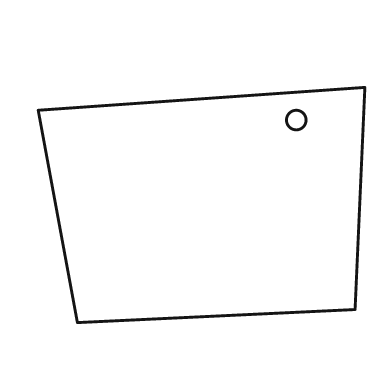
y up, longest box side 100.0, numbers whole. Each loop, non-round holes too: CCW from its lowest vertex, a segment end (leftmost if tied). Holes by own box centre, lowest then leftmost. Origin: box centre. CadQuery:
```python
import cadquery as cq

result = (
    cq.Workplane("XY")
    .moveTo(-38.0, -36.0)
    .lineTo(47.0, -32.0)
    .lineTo(50.0, 36.0)
    .lineTo(-50.0, 29.0)
    .close()
    .moveTo(29.0, 26.0)
    .circle(3.0)
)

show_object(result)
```